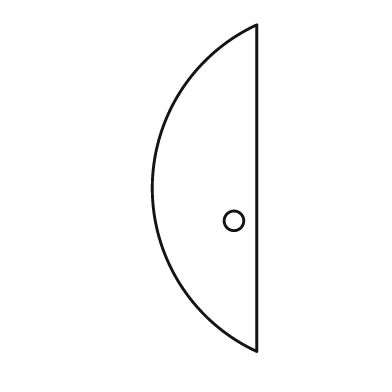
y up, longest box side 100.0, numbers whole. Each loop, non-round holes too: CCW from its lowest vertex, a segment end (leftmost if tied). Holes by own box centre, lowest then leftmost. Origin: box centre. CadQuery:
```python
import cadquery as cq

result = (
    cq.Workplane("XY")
    .moveTo(16.0, -50.0)
    .lineTo(16.0, 50.0)
    .threePointArc((-16.0, 0.0), (16.0, -50.0))
    .close()
    .moveTo(9.0, -10.0)
    .circle(3.0)
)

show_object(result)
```